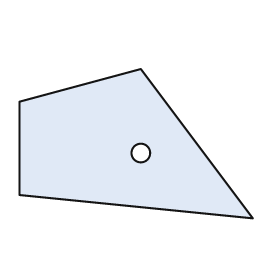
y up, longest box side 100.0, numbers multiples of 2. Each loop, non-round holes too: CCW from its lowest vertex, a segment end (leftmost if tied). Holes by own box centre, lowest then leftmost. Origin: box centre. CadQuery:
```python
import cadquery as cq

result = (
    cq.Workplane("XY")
    .moveTo(50.0, -32.0)
    .lineTo(2.0, 32.0)
    .lineTo(-50.0, 18.0)
    .lineTo(-50.0, -22.0)
    .close()
    .moveTo(2.0, -4.0)
    .circle(4.0)
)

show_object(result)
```